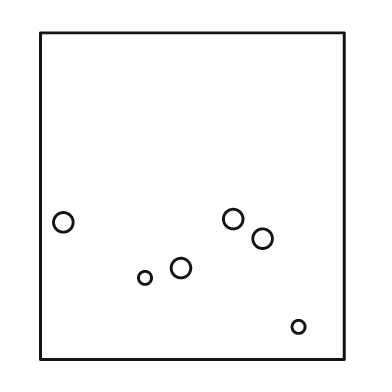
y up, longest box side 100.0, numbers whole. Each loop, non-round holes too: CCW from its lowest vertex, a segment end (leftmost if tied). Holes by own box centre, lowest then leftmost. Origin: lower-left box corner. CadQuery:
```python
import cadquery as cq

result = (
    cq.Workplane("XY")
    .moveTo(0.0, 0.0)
    .lineTo(93.0, 0.0)
    .lineTo(93.0, 100.0)
    .lineTo(0.0, 100.0)
    .close()
    .moveTo(79.0, 10.0)
    .circle(2.0)
    .moveTo(32.0, 25.0)
    .circle(2.0)
    .moveTo(43.0, 28.0)
    .circle(3.0)
    .moveTo(68.0, 37.0)
    .circle(3.0)
    .moveTo(7.0, 42.0)
    .circle(3.0)
    .moveTo(59.0, 43.0)
    .circle(3.0)
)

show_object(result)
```